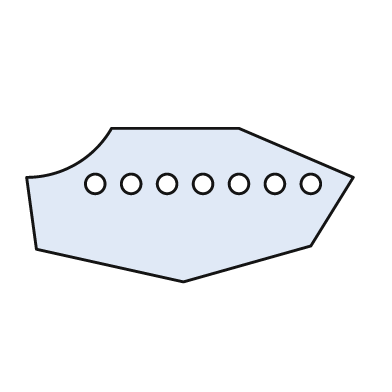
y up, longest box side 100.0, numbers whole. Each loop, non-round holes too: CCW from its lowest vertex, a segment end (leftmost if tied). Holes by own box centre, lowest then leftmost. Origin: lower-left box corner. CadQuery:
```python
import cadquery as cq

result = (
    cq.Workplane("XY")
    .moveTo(48.0, 0.0)
    .lineTo(87.0, 11.0)
    .lineTo(100.0, 32.0)
    .lineTo(65.0, 47.0)
    .lineTo(26.0, 47.0)
    .threePointArc((15.0, 36.0), (0.0, 32.0))
    .lineTo(3.0, 10.0)
    .close()
    .moveTo(21.0, 30.0)
    .circle(3.0)
    .moveTo(32.0, 30.0)
    .circle(3.0)
    .moveTo(43.0, 30.0)
    .circle(3.0)
    .moveTo(54.0, 30.0)
    .circle(3.0)
    .moveTo(65.0, 30.0)
    .circle(3.0)
    .moveTo(76.0, 30.0)
    .circle(3.0)
    .moveTo(87.0, 30.0)
    .circle(3.0)
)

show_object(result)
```